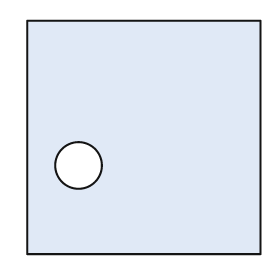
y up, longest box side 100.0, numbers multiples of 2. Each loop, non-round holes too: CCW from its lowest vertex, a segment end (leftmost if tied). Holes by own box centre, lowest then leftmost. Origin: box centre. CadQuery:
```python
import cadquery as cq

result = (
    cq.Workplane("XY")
    .moveTo(-50.0, -50.0)
    .lineTo(50.0, -50.0)
    .lineTo(50.0, 50.0)
    .lineTo(-50.0, 50.0)
    .close()
    .moveTo(-28.0, -12.0)
    .circle(10.0)
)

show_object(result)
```